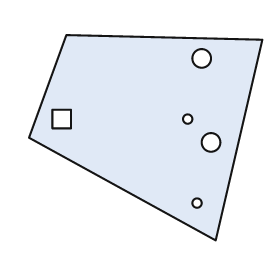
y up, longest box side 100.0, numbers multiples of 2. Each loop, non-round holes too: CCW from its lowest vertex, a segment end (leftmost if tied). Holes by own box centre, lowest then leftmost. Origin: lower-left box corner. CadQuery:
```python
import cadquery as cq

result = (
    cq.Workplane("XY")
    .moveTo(80.0, 0.0)
    .lineTo(100.0, 86.0)
    .lineTo(16.0, 88.0)
    .lineTo(0.0, 44.0)
    .close()
    .moveTo(72.0, 16.0)
    .circle(2.0)
    .moveTo(78.0, 42.0)
    .circle(4.0)
    .moveTo(10.0, 48.0)
    .lineTo(18.0, 48.0)
    .lineTo(18.0, 56.0)
    .lineTo(10.0, 56.0)
    .close()
    .moveTo(68.0, 52.0)
    .circle(2.0)
    .moveTo(74.0, 78.0)
    .circle(4.0)
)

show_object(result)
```